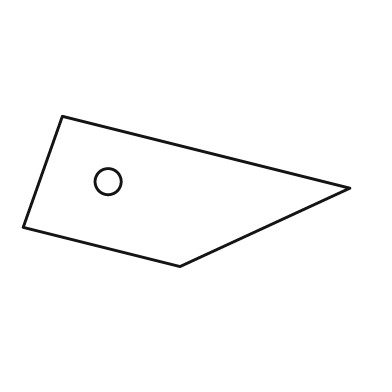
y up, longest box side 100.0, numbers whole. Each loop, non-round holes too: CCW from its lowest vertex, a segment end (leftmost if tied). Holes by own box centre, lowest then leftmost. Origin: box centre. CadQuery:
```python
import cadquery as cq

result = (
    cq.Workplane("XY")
    .moveTo(-2.0, -23.0)
    .lineTo(50.0, 1.0)
    .lineTo(-38.0, 23.0)
    .lineTo(-50.0, -11.0)
    .close()
    .moveTo(-24.0, 3.0)
    .circle(4.0)
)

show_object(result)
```